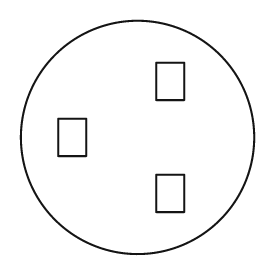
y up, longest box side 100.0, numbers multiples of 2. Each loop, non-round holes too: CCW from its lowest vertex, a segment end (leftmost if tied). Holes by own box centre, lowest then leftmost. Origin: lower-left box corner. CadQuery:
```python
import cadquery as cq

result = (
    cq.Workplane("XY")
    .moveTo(50.0, 50.0)
    .circle(50.0)
    .moveTo(58.0, 18.0)
    .lineTo(70.0, 18.0)
    .lineTo(70.0, 34.0)
    .lineTo(58.0, 34.0)
    .close()
    .moveTo(16.0, 42.0)
    .lineTo(28.0, 42.0)
    .lineTo(28.0, 58.0)
    .lineTo(16.0, 58.0)
    .close()
    .moveTo(58.0, 66.0)
    .lineTo(70.0, 66.0)
    .lineTo(70.0, 82.0)
    .lineTo(58.0, 82.0)
    .close()
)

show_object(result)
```